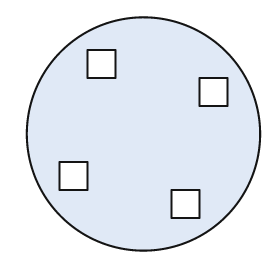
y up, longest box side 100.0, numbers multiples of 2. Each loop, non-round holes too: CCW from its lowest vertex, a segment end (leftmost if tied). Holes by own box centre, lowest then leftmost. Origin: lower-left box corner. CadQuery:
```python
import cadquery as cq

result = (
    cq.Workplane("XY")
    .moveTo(50.0, 50.0)
    .circle(50.0)
    .moveTo(62.0, 14.0)
    .lineTo(74.0, 14.0)
    .lineTo(74.0, 26.0)
    .lineTo(62.0, 26.0)
    .close()
    .moveTo(14.0, 26.0)
    .lineTo(26.0, 26.0)
    .lineTo(26.0, 38.0)
    .lineTo(14.0, 38.0)
    .close()
    .moveTo(74.0, 62.0)
    .lineTo(86.0, 62.0)
    .lineTo(86.0, 74.0)
    .lineTo(74.0, 74.0)
    .close()
    .moveTo(26.0, 74.0)
    .lineTo(38.0, 74.0)
    .lineTo(38.0, 86.0)
    .lineTo(26.0, 86.0)
    .close()
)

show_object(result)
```